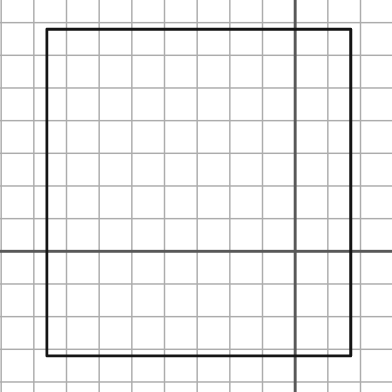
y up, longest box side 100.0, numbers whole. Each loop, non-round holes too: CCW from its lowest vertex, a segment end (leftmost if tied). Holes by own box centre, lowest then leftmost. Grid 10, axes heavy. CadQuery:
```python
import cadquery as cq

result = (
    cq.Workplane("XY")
    .moveTo(-76.0, -32.0)
    .lineTo(17.0, -32.0)
    .lineTo(17.0, 68.0)
    .lineTo(-76.0, 68.0)
    .close()
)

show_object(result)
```